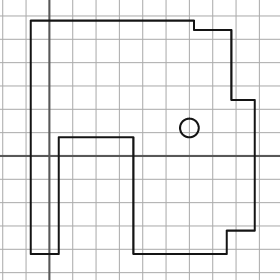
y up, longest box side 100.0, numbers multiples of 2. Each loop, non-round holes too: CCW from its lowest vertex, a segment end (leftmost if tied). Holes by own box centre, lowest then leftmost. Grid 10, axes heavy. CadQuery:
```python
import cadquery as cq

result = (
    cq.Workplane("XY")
    .moveTo(-8.0, -42.0)
    .lineTo(4.0, -42.0)
    .lineTo(4.0, 8.0)
    .lineTo(36.0, 8.0)
    .lineTo(36.0, -42.0)
    .lineTo(76.0, -42.0)
    .lineTo(76.0, -32.0)
    .lineTo(88.0, -32.0)
    .lineTo(88.0, 24.0)
    .lineTo(78.0, 24.0)
    .lineTo(78.0, 54.0)
    .lineTo(62.0, 54.0)
    .lineTo(62.0, 58.0)
    .lineTo(-8.0, 58.0)
    .close()
    .moveTo(60.0, 12.0)
    .circle(4.0)
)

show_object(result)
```